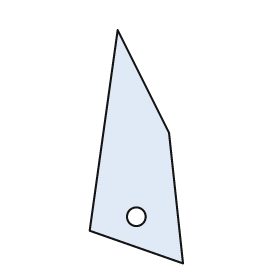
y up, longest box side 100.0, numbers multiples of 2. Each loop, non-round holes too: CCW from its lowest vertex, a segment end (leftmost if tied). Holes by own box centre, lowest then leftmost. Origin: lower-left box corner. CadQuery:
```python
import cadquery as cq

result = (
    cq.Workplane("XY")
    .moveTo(40.0, 0.0)
    .lineTo(34.0, 56.0)
    .lineTo(12.0, 100.0)
    .lineTo(0.0, 14.0)
    .close()
    .moveTo(20.0, 20.0)
    .circle(4.0)
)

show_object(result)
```